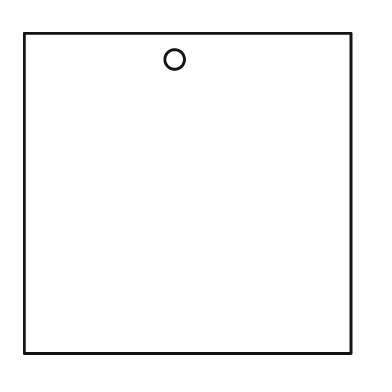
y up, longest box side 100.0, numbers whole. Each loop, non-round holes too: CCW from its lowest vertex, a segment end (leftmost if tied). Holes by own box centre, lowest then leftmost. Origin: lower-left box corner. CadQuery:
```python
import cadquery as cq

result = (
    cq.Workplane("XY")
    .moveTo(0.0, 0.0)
    .lineTo(100.0, 0.0)
    .lineTo(100.0, 98.0)
    .lineTo(0.0, 98.0)
    .close()
    .moveTo(46.0, 90.0)
    .circle(3.0)
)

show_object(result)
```